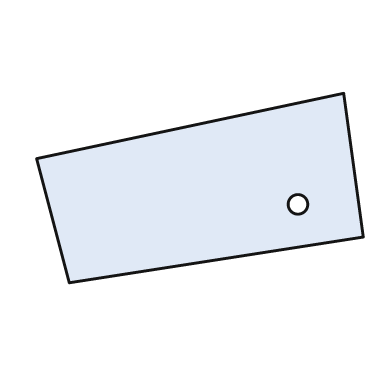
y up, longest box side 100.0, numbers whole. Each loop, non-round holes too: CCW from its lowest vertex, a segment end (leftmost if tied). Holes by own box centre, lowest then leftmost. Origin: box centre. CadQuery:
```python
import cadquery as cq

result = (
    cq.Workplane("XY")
    .moveTo(-40.0, -29.0)
    .lineTo(50.0, -15.0)
    .lineTo(44.0, 29.0)
    .lineTo(-50.0, 9.0)
    .close()
    .moveTo(30.0, -5.0)
    .circle(3.0)
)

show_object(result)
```